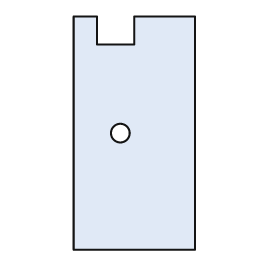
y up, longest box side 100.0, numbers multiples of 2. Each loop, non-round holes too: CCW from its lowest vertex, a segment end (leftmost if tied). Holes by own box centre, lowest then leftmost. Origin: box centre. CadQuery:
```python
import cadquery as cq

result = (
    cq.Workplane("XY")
    .moveTo(-26.0, -50.0)
    .lineTo(26.0, -50.0)
    .lineTo(26.0, 50.0)
    .lineTo(0.0, 50.0)
    .lineTo(0.0, 38.0)
    .lineTo(-16.0, 38.0)
    .lineTo(-16.0, 50.0)
    .lineTo(-26.0, 50.0)
    .close()
    .moveTo(-6.0, 0.0)
    .circle(4.0)
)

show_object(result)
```